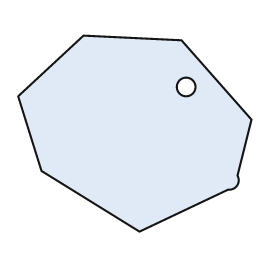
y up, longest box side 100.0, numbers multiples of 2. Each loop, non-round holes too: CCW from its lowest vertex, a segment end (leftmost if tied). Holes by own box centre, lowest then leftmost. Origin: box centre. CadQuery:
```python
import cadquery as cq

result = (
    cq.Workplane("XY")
    .moveTo(2.0, -42.0)
    .lineTo(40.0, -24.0)
    .threePointArc((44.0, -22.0), (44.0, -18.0))
    .lineTo(50.0, 6.0)
    .lineTo(20.0, 40.0)
    .lineTo(-22.0, 42.0)
    .lineTo(-50.0, 16.0)
    .lineTo(-40.0, -16.0)
    .close()
    .moveTo(22.0, 20.0)
    .circle(4.0)
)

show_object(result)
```